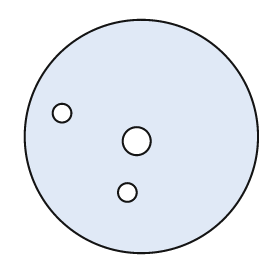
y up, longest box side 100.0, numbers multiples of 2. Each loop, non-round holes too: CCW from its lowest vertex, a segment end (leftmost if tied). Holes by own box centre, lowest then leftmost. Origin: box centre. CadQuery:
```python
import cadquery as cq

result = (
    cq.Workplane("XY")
    .moveTo(0.0, 0.0)
    .circle(50.0)
    .moveTo(-6.0, -24.0)
    .circle(4.0)
    .moveTo(-2.0, -2.0)
    .circle(6.0)
    .moveTo(-34.0, 10.0)
    .circle(4.0)
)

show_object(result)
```